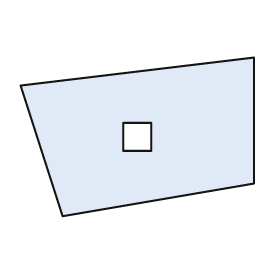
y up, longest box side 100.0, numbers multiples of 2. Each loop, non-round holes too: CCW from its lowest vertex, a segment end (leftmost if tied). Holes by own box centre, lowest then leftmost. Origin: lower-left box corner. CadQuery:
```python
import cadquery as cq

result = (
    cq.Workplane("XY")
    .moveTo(18.0, 0.0)
    .lineTo(100.0, 14.0)
    .lineTo(100.0, 68.0)
    .lineTo(0.0, 56.0)
    .close()
    .moveTo(44.0, 28.0)
    .lineTo(56.0, 28.0)
    .lineTo(56.0, 40.0)
    .lineTo(44.0, 40.0)
    .close()
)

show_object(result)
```